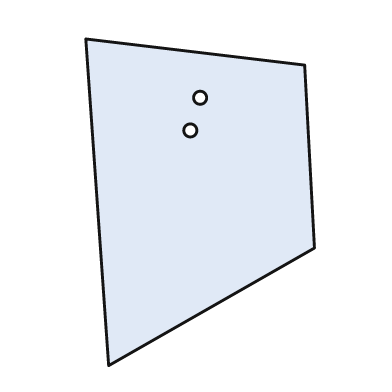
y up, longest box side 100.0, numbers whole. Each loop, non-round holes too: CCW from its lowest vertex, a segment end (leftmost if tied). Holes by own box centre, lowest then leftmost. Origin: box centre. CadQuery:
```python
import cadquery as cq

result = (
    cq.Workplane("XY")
    .moveTo(-28.0, -50.0)
    .lineTo(35.0, -14.0)
    .lineTo(32.0, 42.0)
    .lineTo(-35.0, 50.0)
    .close()
    .moveTo(-3.0, 22.0)
    .circle(2.0)
    .moveTo(0.0, 32.0)
    .circle(2.0)
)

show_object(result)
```